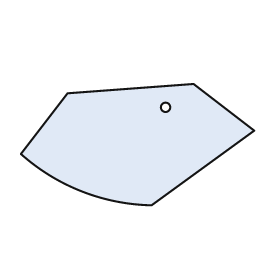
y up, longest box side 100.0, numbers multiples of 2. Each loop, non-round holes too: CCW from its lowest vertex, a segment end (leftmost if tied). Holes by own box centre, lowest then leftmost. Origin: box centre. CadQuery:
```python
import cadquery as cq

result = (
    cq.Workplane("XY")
    .moveTo(6.0, -26.0)
    .lineTo(50.0, 6.0)
    .lineTo(24.0, 26.0)
    .lineTo(-30.0, 22.0)
    .lineTo(-50.0, -4.0)
    .threePointArc((-24.0, -20.0), (6.0, -26.0))
    .close()
    .moveTo(12.0, 16.0)
    .circle(2.0)
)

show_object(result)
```